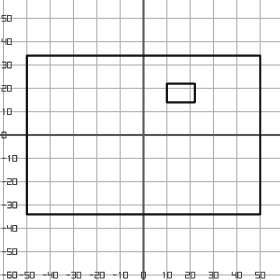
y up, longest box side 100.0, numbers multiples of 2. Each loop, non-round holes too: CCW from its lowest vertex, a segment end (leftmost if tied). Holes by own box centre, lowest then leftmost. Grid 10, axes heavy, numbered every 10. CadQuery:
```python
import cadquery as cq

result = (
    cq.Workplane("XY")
    .moveTo(-50.0, -34.0)
    .lineTo(50.0, -34.0)
    .lineTo(50.0, 34.0)
    .lineTo(-50.0, 34.0)
    .close()
    .moveTo(10.0, 14.0)
    .lineTo(22.0, 14.0)
    .lineTo(22.0, 22.0)
    .lineTo(10.0, 22.0)
    .close()
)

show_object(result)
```